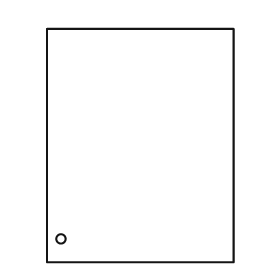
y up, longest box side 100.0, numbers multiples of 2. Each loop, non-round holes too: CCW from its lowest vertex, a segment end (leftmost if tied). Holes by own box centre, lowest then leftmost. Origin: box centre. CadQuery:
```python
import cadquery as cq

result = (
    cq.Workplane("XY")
    .moveTo(-40.0, -50.0)
    .lineTo(40.0, -50.0)
    .lineTo(40.0, 50.0)
    .lineTo(-40.0, 50.0)
    .close()
    .moveTo(-34.0, -40.0)
    .circle(2.0)
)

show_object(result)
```